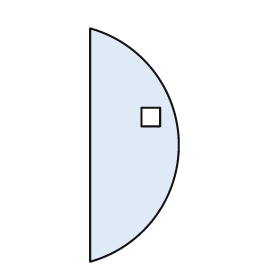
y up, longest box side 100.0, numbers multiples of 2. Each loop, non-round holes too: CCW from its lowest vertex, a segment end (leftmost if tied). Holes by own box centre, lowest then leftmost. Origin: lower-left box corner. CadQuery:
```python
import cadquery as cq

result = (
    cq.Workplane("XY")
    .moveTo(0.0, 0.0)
    .threePointArc((38.0, 50.0), (0.0, 100.0))
    .close()
    .moveTo(22.0, 58.0)
    .lineTo(30.0, 58.0)
    .lineTo(30.0, 66.0)
    .lineTo(22.0, 66.0)
    .close()
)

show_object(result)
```